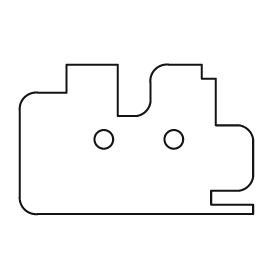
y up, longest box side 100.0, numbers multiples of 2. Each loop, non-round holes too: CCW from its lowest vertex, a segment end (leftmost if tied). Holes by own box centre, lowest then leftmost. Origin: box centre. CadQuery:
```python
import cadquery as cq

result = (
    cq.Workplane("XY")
    .moveTo(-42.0, -32.0)
    .lineTo(50.0, -32.0)
    .lineTo(50.0, -28.0)
    .lineTo(32.0, -28.0)
    .lineTo(32.0, -22.0)
    .lineTo(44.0, -22.0)
    .threePointArc((48.0, -20.0), (50.0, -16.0))
    .lineTo(50.0, 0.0)
    .threePointArc((48.0, 4.0), (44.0, 6.0))
    .lineTo(34.0, 6.0)
    .lineTo(34.0, 26.0)
    .lineTo(28.0, 26.0)
    .lineTo(28.0, 32.0)
    .lineTo(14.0, 32.0)
    .threePointArc((8.0, 30.0), (6.0, 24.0))
    .lineTo(6.0, 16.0)
    .threePointArc((4.0, 12.0), (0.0, 10.0))
    .lineTo(-8.0, 10.0)
    .lineTo(-8.0, 32.0)
    .lineTo(-30.0, 32.0)
    .lineTo(-30.0, 20.0)
    .lineTo(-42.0, 20.0)
    .threePointArc((-48.0, 18.0), (-50.0, 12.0))
    .lineTo(-50.0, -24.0)
    .threePointArc((-48.0, -30.0), (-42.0, -32.0))
    .close()
    .moveTo(-14.0, 0.0)
    .circle(4.0)
    .moveTo(16.0, 0.0)
    .circle(4.0)
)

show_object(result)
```